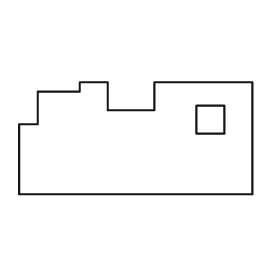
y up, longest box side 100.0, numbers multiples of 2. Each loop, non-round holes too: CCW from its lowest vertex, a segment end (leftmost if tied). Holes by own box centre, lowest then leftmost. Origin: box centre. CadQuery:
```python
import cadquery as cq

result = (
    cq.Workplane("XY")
    .moveTo(-50.0, -24.0)
    .lineTo(50.0, -24.0)
    .lineTo(50.0, 24.0)
    .lineTo(8.0, 24.0)
    .lineTo(8.0, 12.0)
    .lineTo(-12.0, 12.0)
    .lineTo(-12.0, 24.0)
    .lineTo(-24.0, 24.0)
    .lineTo(-24.0, 20.0)
    .lineTo(-42.0, 20.0)
    .lineTo(-42.0, 6.0)
    .lineTo(-50.0, 6.0)
    .close()
    .moveTo(26.0, 2.0)
    .lineTo(38.0, 2.0)
    .lineTo(38.0, 14.0)
    .lineTo(26.0, 14.0)
    .close()
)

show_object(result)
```